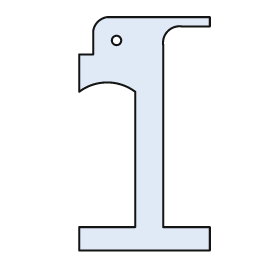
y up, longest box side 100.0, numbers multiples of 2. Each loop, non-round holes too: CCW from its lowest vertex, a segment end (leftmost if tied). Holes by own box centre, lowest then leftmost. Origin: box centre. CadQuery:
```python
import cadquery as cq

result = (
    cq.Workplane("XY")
    .moveTo(-28.0, -50.0)
    .lineTo(28.0, -50.0)
    .lineTo(28.0, -40.0)
    .lineTo(8.0, -40.0)
    .lineTo(8.0, 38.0)
    .threePointArc((10.0, 44.0), (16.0, 46.0))
    .lineTo(28.0, 46.0)
    .lineTo(28.0, 50.0)
    .lineTo(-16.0, 50.0)
    .threePointArc((-20.0, 48.0), (-22.0, 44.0))
    .lineTo(-22.0, 34.0)
    .lineTo(-28.0, 34.0)
    .lineTo(-28.0, 18.0)
    .threePointArc((-16.0, 22.0), (-4.0, 18.0))
    .lineTo(-4.0, -40.0)
    .lineTo(-28.0, -40.0)
    .close()
    .moveTo(-12.0, 40.0)
    .circle(2.0)
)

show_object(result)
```